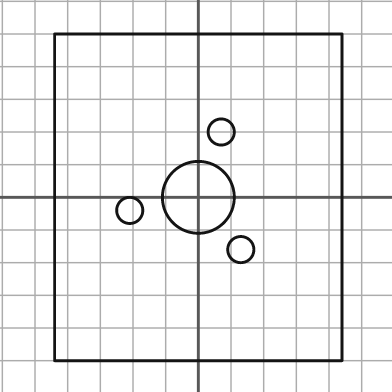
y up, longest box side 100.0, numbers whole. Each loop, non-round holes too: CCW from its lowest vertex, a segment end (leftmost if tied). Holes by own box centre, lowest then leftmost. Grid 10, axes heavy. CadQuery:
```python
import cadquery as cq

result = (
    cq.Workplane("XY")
    .moveTo(-44.0, -50.0)
    .lineTo(44.0, -50.0)
    .lineTo(44.0, 50.0)
    .lineTo(-44.0, 50.0)
    .close()
    .moveTo(13.0, -16.0)
    .circle(4.0)
    .moveTo(-21.0, -4.0)
    .circle(4.0)
    .moveTo(0.0, 0.0)
    .circle(11.0)
    .moveTo(7.0, 20.0)
    .circle(4.0)
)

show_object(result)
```